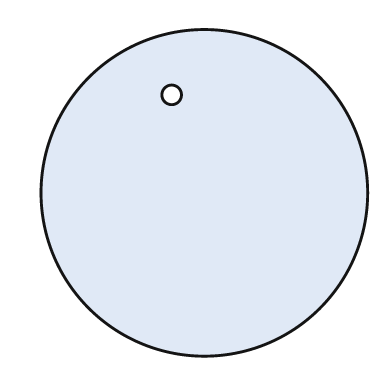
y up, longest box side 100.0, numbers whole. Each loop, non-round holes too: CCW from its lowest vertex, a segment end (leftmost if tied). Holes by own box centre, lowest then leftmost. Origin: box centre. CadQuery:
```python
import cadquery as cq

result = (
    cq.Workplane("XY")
    .moveTo(0.0, 0.0)
    .circle(50.0)
    .moveTo(-10.0, 30.0)
    .circle(3.0)
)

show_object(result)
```